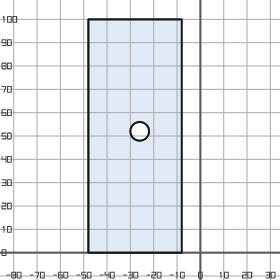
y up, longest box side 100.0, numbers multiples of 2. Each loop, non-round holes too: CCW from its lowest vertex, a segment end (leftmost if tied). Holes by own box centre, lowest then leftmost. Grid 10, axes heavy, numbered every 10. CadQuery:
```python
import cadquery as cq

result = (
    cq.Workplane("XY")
    .moveTo(-48.0, 0.0)
    .lineTo(-8.0, 0.0)
    .lineTo(-8.0, 100.0)
    .lineTo(-48.0, 100.0)
    .close()
    .moveTo(-26.0, 52.0)
    .circle(4.0)
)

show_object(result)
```